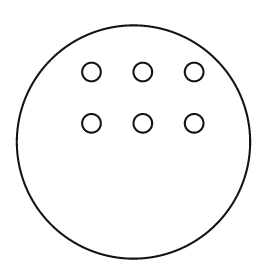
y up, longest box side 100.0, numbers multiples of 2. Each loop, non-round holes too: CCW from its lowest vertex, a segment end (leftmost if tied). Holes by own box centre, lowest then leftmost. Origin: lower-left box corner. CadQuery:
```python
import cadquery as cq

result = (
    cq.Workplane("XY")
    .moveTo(50.0, 50.0)
    .circle(50.0)
    .moveTo(32.0, 58.0)
    .circle(4.0)
    .moveTo(54.0, 58.0)
    .circle(4.0)
    .moveTo(76.0, 58.0)
    .circle(4.0)
    .moveTo(32.0, 80.0)
    .circle(4.0)
    .moveTo(54.0, 80.0)
    .circle(4.0)
    .moveTo(76.0, 80.0)
    .circle(4.0)
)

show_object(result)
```